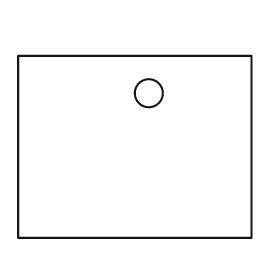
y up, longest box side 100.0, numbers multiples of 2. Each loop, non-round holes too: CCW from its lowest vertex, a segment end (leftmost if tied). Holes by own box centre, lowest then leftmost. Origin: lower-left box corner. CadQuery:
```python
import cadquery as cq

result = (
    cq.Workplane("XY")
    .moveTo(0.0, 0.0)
    .lineTo(100.0, 0.0)
    .lineTo(100.0, 78.0)
    .lineTo(0.0, 78.0)
    .close()
    .moveTo(56.0, 62.0)
    .circle(6.0)
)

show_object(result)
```